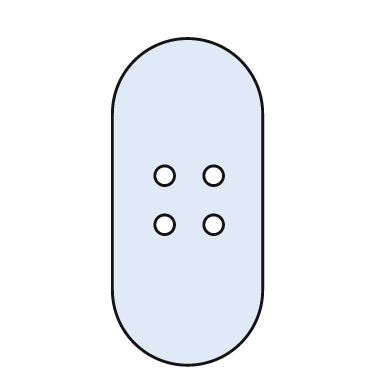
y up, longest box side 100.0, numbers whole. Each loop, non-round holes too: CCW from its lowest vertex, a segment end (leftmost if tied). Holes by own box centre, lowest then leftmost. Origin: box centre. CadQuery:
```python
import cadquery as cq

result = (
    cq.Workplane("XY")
    .moveTo(-23.0, -27.0)
    .threePointArc((0.0, -50.0), (23.0, -27.0))
    .lineTo(23.0, 27.0)
    .threePointArc((0.0, 50.0), (-23.0, 27.0))
    .close()
    .moveTo(-7.0, -7.0)
    .circle(3.0)
    .moveTo(8.0, -7.0)
    .circle(3.0)
    .moveTo(-7.0, 8.0)
    .circle(3.0)
    .moveTo(8.0, 8.0)
    .circle(3.0)
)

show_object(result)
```